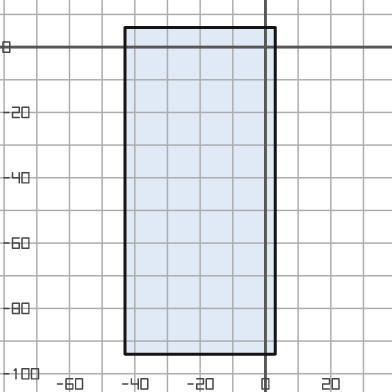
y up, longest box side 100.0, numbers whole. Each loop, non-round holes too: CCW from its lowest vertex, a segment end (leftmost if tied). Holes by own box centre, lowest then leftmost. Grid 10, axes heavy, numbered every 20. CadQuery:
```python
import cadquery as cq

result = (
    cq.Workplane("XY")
    .moveTo(-43.0, -94.0)
    .lineTo(3.0, -94.0)
    .lineTo(3.0, 6.0)
    .lineTo(-43.0, 6.0)
    .close()
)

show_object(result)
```